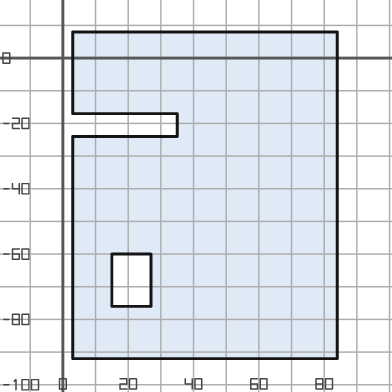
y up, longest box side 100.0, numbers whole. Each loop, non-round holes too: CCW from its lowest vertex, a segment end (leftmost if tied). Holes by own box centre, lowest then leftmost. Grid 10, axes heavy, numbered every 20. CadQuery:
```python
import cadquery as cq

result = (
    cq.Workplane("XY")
    .moveTo(3.0, -92.0)
    .lineTo(84.0, -92.0)
    .lineTo(84.0, 8.0)
    .lineTo(3.0, 8.0)
    .lineTo(3.0, -17.0)
    .lineTo(35.0, -17.0)
    .lineTo(35.0, -24.0)
    .lineTo(3.0, -24.0)
    .close()
    .moveTo(15.0, -76.0)
    .lineTo(27.0, -76.0)
    .lineTo(27.0, -60.0)
    .lineTo(15.0, -60.0)
    .close()
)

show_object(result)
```